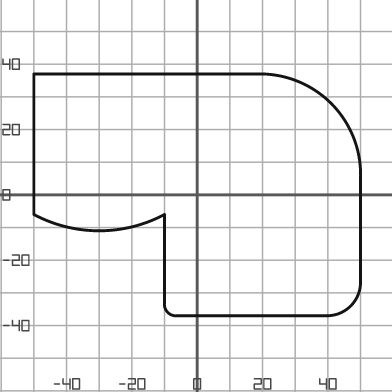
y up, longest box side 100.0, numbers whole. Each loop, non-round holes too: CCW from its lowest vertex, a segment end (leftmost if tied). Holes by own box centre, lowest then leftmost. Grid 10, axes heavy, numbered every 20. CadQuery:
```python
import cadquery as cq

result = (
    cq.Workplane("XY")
    .moveTo(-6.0, -37.0)
    .lineTo(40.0, -37.0)
    .threePointArc((47.0, -34.0), (50.0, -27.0))
    .lineTo(50.0, 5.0)
    .threePointArc((41.0, 28.0), (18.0, 37.0))
    .lineTo(-50.0, 37.0)
    .lineTo(-50.0, -6.0)
    .threePointArc((-30.0, -11.0), (-10.0, -6.0))
    .lineTo(-10.0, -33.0)
    .threePointArc((-9.0, -36.0), (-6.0, -37.0))
    .close()
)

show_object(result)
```